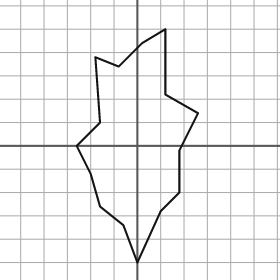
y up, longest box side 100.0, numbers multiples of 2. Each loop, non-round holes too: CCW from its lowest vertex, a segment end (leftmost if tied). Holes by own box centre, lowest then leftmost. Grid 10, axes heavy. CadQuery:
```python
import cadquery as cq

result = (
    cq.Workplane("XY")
    .moveTo(0.0, -50.0)
    .lineTo(10.0, -28.0)
    .lineTo(18.0, -20.0)
    .lineTo(18.0, -2.0)
    .lineTo(26.0, 14.0)
    .lineTo(12.0, 22.0)
    .lineTo(12.0, 50.0)
    .lineTo(2.0, 44.0)
    .lineTo(-8.0, 34.0)
    .lineTo(-18.0, 38.0)
    .lineTo(-16.0, 10.0)
    .lineTo(-26.0, 0.0)
    .lineTo(-20.0, -12.0)
    .lineTo(-16.0, -26.0)
    .lineTo(-6.0, -34.0)
    .close()
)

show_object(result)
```